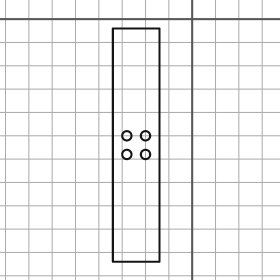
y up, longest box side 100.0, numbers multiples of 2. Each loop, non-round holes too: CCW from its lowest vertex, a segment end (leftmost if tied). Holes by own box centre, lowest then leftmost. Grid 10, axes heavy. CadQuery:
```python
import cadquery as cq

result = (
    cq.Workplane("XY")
    .moveTo(-34.0, -104.0)
    .lineTo(-14.0, -104.0)
    .lineTo(-14.0, -4.0)
    .lineTo(-34.0, -4.0)
    .close()
    .moveTo(-28.0, -58.0)
    .circle(2.0)
    .moveTo(-20.0, -58.0)
    .circle(2.0)
    .moveTo(-28.0, -50.0)
    .circle(2.0)
    .moveTo(-20.0, -50.0)
    .circle(2.0)
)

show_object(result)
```